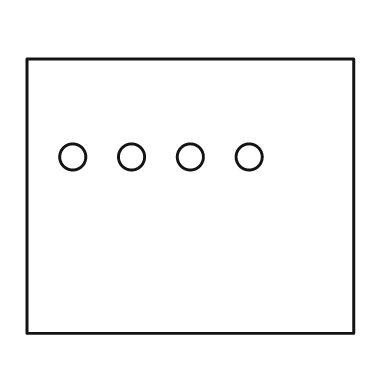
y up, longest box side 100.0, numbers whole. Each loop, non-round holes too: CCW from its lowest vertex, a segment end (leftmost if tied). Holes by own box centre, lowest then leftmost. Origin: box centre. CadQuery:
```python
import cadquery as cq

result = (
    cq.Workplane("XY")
    .moveTo(-50.0, -42.0)
    .lineTo(50.0, -42.0)
    .lineTo(50.0, 42.0)
    .lineTo(-50.0, 42.0)
    .close()
    .moveTo(-36.0, 12.0)
    .circle(4.0)
    .moveTo(-18.0, 12.0)
    .circle(4.0)
    .moveTo(0.0, 12.0)
    .circle(4.0)
    .moveTo(18.0, 12.0)
    .circle(4.0)
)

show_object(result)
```